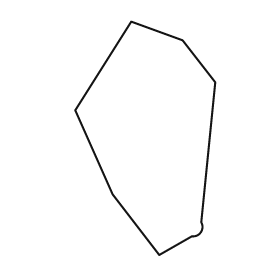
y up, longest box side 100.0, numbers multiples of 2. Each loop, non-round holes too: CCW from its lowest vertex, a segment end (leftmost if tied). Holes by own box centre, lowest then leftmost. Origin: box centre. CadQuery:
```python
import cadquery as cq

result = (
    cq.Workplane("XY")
    .moveTo(6.0, -50.0)
    .lineTo(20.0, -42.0)
    .threePointArc((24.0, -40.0), (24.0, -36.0))
    .lineTo(30.0, 24.0)
    .lineTo(16.0, 42.0)
    .lineTo(-6.0, 50.0)
    .lineTo(-30.0, 12.0)
    .lineTo(-14.0, -24.0)
    .close()
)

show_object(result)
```